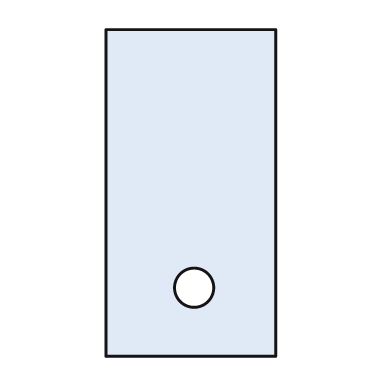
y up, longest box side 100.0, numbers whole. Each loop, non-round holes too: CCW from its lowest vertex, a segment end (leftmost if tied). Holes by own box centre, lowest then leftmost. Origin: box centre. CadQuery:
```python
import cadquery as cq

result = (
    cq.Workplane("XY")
    .moveTo(-26.0, -50.0)
    .lineTo(26.0, -50.0)
    .lineTo(26.0, 50.0)
    .lineTo(-26.0, 50.0)
    .close()
    .moveTo(1.0, -29.0)
    .circle(6.0)
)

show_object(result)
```